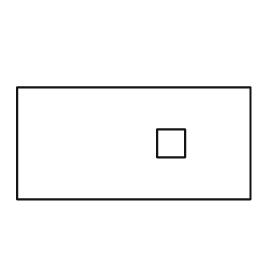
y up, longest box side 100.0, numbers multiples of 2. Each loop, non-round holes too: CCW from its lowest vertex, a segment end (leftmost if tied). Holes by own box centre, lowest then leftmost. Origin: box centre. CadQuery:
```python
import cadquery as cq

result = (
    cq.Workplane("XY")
    .moveTo(-50.0, -24.0)
    .lineTo(50.0, -24.0)
    .lineTo(50.0, 24.0)
    .lineTo(-50.0, 24.0)
    .close()
    .moveTo(10.0, -6.0)
    .lineTo(22.0, -6.0)
    .lineTo(22.0, 6.0)
    .lineTo(10.0, 6.0)
    .close()
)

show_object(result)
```